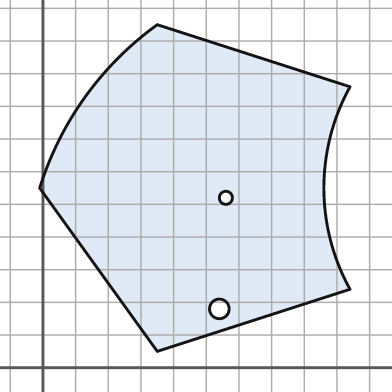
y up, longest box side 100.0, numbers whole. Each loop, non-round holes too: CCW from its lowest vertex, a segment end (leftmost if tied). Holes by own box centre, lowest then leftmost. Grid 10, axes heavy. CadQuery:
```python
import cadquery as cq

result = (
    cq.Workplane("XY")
    .moveTo(35.0, 5.0)
    .lineTo(94.0, 24.0)
    .threePointArc((86.0, 55.0), (94.0, 86.0))
    .lineTo(35.0, 105.0)
    .threePointArc((13.0, 83.0), (-1.0, 55.0))
    .close()
    .moveTo(54.0, 18.0)
    .circle(3.0)
    .moveTo(56.0, 52.0)
    .circle(2.0)
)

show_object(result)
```